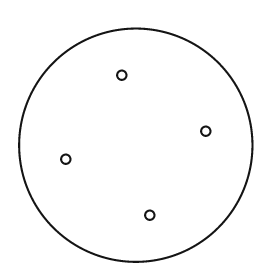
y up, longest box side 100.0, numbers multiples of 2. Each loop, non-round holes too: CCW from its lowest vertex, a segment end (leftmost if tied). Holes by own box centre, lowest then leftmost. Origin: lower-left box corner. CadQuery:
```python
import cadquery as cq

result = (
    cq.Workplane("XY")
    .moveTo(50.0, 50.0)
    .circle(50.0)
    .moveTo(56.0, 20.0)
    .circle(2.0)
    .moveTo(20.0, 44.0)
    .circle(2.0)
    .moveTo(80.0, 56.0)
    .circle(2.0)
    .moveTo(44.0, 80.0)
    .circle(2.0)
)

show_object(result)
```